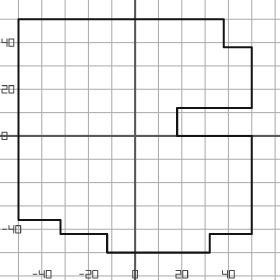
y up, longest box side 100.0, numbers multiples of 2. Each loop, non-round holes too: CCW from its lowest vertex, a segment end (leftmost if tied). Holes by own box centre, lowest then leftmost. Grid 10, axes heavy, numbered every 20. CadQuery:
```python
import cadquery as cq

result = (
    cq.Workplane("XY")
    .moveTo(-12.0, -50.0)
    .lineTo(32.0, -50.0)
    .lineTo(32.0, -42.0)
    .lineTo(50.0, -42.0)
    .lineTo(50.0, 0.0)
    .lineTo(18.0, 0.0)
    .lineTo(18.0, 12.0)
    .lineTo(50.0, 12.0)
    .lineTo(50.0, 38.0)
    .lineTo(38.0, 38.0)
    .lineTo(38.0, 50.0)
    .lineTo(-50.0, 50.0)
    .lineTo(-50.0, -36.0)
    .lineTo(-32.0, -36.0)
    .lineTo(-32.0, -42.0)
    .lineTo(-12.0, -42.0)
    .close()
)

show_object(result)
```